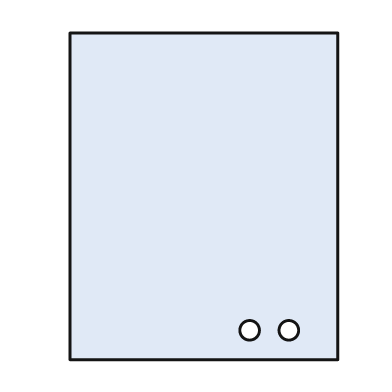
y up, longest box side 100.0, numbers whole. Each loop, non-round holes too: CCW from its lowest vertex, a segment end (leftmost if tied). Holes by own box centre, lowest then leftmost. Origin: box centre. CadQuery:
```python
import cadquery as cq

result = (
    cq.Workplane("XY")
    .moveTo(-41.0, -50.0)
    .lineTo(41.0, -50.0)
    .lineTo(41.0, 50.0)
    .lineTo(-41.0, 50.0)
    .close()
    .moveTo(14.0, -41.0)
    .circle(3.0)
    .moveTo(26.0, -41.0)
    .circle(3.0)
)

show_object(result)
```